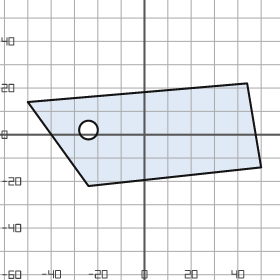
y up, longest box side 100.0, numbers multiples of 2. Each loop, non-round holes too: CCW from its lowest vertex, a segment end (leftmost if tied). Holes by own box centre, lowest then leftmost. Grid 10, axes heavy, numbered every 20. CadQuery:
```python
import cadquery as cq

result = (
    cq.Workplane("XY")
    .moveTo(-24.0, -22.0)
    .lineTo(50.0, -14.0)
    .lineTo(44.0, 22.0)
    .lineTo(-50.0, 14.0)
    .close()
    .moveTo(-24.0, 2.0)
    .circle(4.0)
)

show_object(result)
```